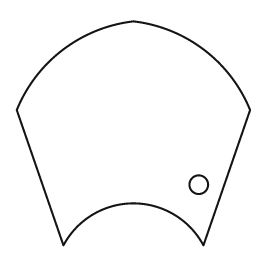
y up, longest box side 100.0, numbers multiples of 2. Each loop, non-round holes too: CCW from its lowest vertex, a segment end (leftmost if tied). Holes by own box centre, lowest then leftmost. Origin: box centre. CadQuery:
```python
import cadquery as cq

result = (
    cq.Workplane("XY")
    .moveTo(-30.0, -48.0)
    .threePointArc((0.0, -30.0), (30.0, -48.0))
    .lineTo(50.0, 10.0)
    .threePointArc((30.0, 36.0), (0.0, 48.0))
    .threePointArc((-30.0, 36.0), (-50.0, 10.0))
    .close()
    .moveTo(28.0, -22.0)
    .circle(4.0)
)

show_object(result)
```